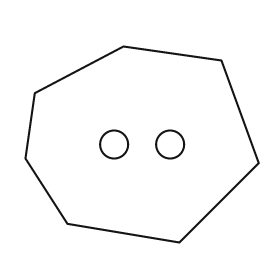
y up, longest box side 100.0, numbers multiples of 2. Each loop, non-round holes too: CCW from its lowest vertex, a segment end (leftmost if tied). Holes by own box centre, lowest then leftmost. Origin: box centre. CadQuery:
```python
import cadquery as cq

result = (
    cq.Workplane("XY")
    .moveTo(16.0, -42.0)
    .lineTo(50.0, -8.0)
    .lineTo(34.0, 36.0)
    .lineTo(-8.0, 42.0)
    .lineTo(-46.0, 22.0)
    .lineTo(-50.0, -6.0)
    .lineTo(-32.0, -34.0)
    .close()
    .moveTo(-12.0, 0.0)
    .circle(6.0)
    .moveTo(12.0, 0.0)
    .circle(6.0)
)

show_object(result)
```